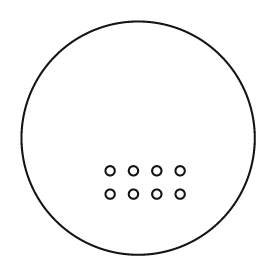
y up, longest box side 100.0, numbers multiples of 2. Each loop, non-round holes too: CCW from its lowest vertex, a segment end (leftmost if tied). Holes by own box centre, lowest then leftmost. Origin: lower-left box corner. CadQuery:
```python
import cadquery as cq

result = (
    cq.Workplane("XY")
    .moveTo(50.0, 50.0)
    .circle(50.0)
    .moveTo(38.0, 26.0)
    .circle(2.0)
    .moveTo(48.0, 26.0)
    .circle(2.0)
    .moveTo(58.0, 26.0)
    .circle(2.0)
    .moveTo(68.0, 26.0)
    .circle(2.0)
    .moveTo(38.0, 36.0)
    .circle(2.0)
    .moveTo(48.0, 36.0)
    .circle(2.0)
    .moveTo(58.0, 36.0)
    .circle(2.0)
    .moveTo(68.0, 36.0)
    .circle(2.0)
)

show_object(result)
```